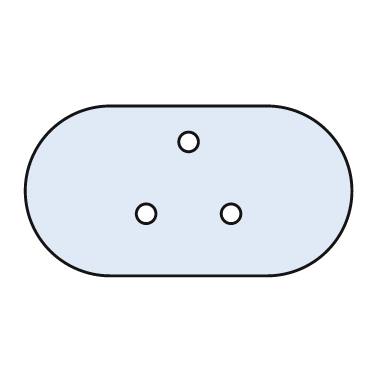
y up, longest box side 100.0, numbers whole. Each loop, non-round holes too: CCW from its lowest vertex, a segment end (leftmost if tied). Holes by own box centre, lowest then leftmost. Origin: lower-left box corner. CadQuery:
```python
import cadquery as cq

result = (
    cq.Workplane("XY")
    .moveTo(26.0, 0.0)
    .lineTo(74.0, 0.0)
    .threePointArc((100.0, 26.0), (74.0, 52.0))
    .lineTo(26.0, 52.0)
    .threePointArc((0.0, 26.0), (26.0, 0.0))
    .close()
    .moveTo(37.0, 19.0)
    .circle(3.0)
    .moveTo(63.0, 19.0)
    .circle(3.0)
    .moveTo(50.0, 41.0)
    .circle(3.0)
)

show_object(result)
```